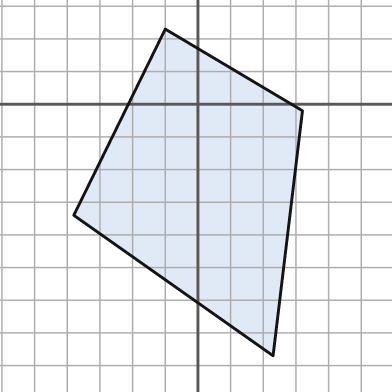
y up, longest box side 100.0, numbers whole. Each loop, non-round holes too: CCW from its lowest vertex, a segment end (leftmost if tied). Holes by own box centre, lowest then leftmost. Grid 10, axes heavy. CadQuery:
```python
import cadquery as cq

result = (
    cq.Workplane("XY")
    .moveTo(23.0, -77.0)
    .lineTo(32.0, -2.0)
    .lineTo(-10.0, 23.0)
    .lineTo(-38.0, -34.0)
    .close()
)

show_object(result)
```